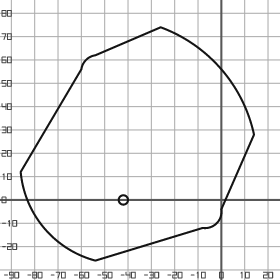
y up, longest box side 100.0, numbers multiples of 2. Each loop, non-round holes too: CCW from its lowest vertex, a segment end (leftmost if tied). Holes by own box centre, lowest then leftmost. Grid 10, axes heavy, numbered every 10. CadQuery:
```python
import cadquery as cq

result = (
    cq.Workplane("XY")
    .moveTo(-54.0, -26.0)
    .lineTo(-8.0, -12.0)
    .threePointArc((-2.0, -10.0), (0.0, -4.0))
    .lineTo(14.0, 28.0)
    .threePointArc((0.0, 56.0), (-26.0, 74.0))
    .lineTo(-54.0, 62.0)
    .threePointArc((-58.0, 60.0), (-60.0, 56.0))
    .lineTo(-86.0, 12.0)
    .threePointArc((-76.0, -12.0), (-54.0, -26.0))
    .close()
    .moveTo(-42.0, 0.0)
    .circle(2.0)
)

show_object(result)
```